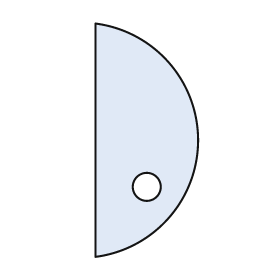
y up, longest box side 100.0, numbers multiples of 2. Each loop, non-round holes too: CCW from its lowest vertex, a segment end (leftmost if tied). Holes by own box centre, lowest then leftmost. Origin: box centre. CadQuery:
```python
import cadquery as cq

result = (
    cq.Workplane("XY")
    .moveTo(-22.0, -50.0)
    .threePointArc((22.0, 0.0), (-22.0, 50.0))
    .close()
    .moveTo(0.0, -20.0)
    .circle(6.0)
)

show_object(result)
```